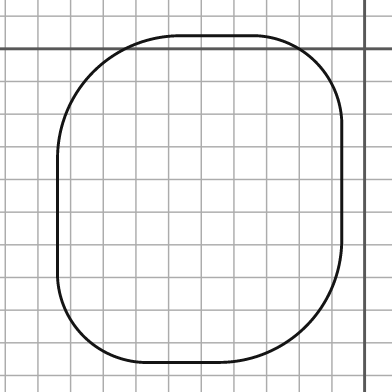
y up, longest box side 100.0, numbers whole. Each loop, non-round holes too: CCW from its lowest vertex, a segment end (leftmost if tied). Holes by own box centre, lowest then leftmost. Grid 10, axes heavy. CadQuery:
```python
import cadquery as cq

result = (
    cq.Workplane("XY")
    .moveTo(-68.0, -96.0)
    .lineTo(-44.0, -96.0)
    .threePointArc((-18.0, -85.0), (-7.0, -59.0))
    .lineTo(-7.0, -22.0)
    .threePointArc((-15.0, -4.0), (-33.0, 4.0))
    .lineTo(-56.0, 4.0)
    .threePointArc((-83.0, -7.0), (-94.0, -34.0))
    .lineTo(-94.0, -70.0)
    .threePointArc((-86.0, -88.0), (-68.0, -96.0))
    .close()
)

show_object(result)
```